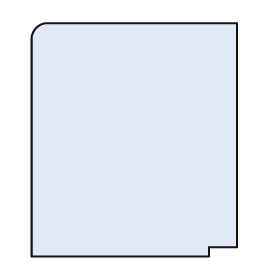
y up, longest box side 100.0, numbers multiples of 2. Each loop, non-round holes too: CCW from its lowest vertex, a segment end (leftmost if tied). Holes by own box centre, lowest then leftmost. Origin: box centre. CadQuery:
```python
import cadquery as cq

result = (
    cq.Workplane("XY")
    .moveTo(-44.0, -50.0)
    .lineTo(32.0, -50.0)
    .lineTo(32.0, -46.0)
    .lineTo(44.0, -46.0)
    .lineTo(44.0, 50.0)
    .lineTo(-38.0, 50.0)
    .threePointArc((-42.0, 48.0), (-44.0, 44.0))
    .close()
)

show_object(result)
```